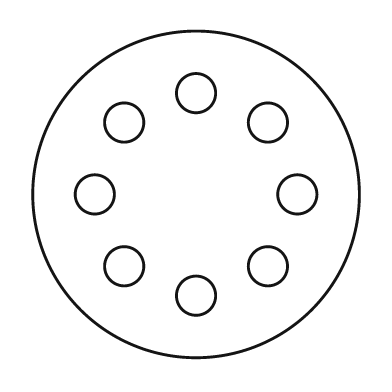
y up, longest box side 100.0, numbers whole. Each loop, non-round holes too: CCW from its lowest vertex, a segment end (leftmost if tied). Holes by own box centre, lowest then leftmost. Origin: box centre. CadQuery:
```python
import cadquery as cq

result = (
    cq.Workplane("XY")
    .moveTo(0.0, 0.0)
    .circle(50.0)
    .moveTo(0.0, -31.0)
    .circle(6.0)
    .moveTo(-22.0, -22.0)
    .circle(6.0)
    .moveTo(22.0, -22.0)
    .circle(6.0)
    .moveTo(-31.0, 0.0)
    .circle(6.0)
    .moveTo(31.0, 0.0)
    .circle(6.0)
    .moveTo(-22.0, 22.0)
    .circle(6.0)
    .moveTo(22.0, 22.0)
    .circle(6.0)
    .moveTo(0.0, 31.0)
    .circle(6.0)
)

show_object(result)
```